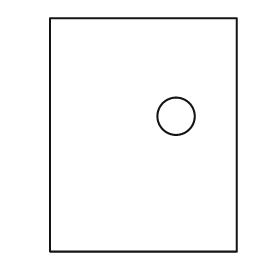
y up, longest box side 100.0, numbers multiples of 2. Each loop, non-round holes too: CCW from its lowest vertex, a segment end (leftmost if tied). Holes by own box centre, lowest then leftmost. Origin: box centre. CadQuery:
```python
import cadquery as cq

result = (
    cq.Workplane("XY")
    .moveTo(-40.0, -50.0)
    .lineTo(40.0, -50.0)
    .lineTo(40.0, 50.0)
    .lineTo(-40.0, 50.0)
    .close()
    .moveTo(14.0, 8.0)
    .circle(8.0)
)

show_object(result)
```